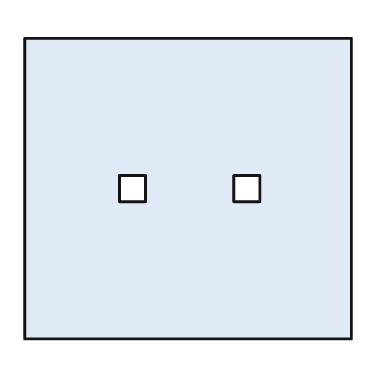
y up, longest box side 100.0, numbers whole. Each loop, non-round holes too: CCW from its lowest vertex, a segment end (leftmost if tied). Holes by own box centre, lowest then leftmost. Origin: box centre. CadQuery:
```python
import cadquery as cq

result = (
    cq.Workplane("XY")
    .moveTo(-50.0, -46.0)
    .lineTo(50.0, -46.0)
    .lineTo(50.0, 46.0)
    .lineTo(-50.0, 46.0)
    .close()
    .moveTo(-21.0, -4.0)
    .lineTo(-13.0, -4.0)
    .lineTo(-13.0, 4.0)
    .lineTo(-21.0, 4.0)
    .close()
    .moveTo(14.0, -4.0)
    .lineTo(22.0, -4.0)
    .lineTo(22.0, 4.0)
    .lineTo(14.0, 4.0)
    .close()
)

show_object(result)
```